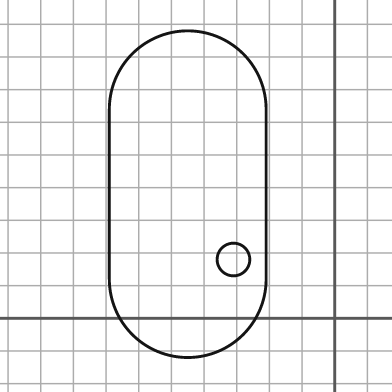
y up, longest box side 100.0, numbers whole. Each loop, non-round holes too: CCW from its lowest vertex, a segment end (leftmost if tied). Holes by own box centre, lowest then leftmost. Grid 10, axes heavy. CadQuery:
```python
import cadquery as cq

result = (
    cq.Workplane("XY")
    .moveTo(-69.0, 12.0)
    .threePointArc((-45.0, -12.0), (-21.0, 12.0))
    .lineTo(-21.0, 64.0)
    .threePointArc((-45.0, 88.0), (-69.0, 64.0))
    .close()
    .moveTo(-31.0, 18.0)
    .circle(5.0)
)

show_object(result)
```